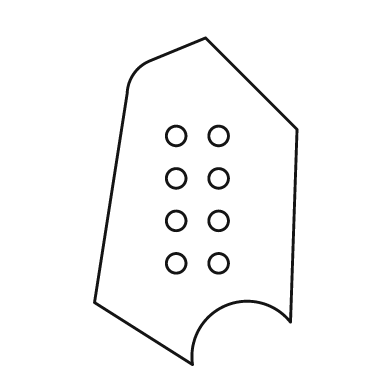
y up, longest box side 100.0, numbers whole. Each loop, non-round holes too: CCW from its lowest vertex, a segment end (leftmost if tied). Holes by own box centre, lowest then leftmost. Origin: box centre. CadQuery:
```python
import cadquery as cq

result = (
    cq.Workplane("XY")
    .moveTo(-1.0, -50.0)
    .threePointArc((9.0, -32.0), (29.0, -37.0))
    .lineTo(31.0, 22.0)
    .lineTo(3.0, 50.0)
    .lineTo(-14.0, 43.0)
    .threePointArc((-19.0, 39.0), (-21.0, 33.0))
    .lineTo(-31.0, -31.0)
    .close()
    .moveTo(-6.0, -19.0)
    .circle(3.0)
    .moveTo(7.0, -19.0)
    .circle(3.0)
    .moveTo(-6.0, -6.0)
    .circle(3.0)
    .moveTo(7.0, -6.0)
    .circle(3.0)
    .moveTo(-6.0, 7.0)
    .circle(3.0)
    .moveTo(7.0, 7.0)
    .circle(3.0)
    .moveTo(-6.0, 20.0)
    .circle(3.0)
    .moveTo(7.0, 20.0)
    .circle(3.0)
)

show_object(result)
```